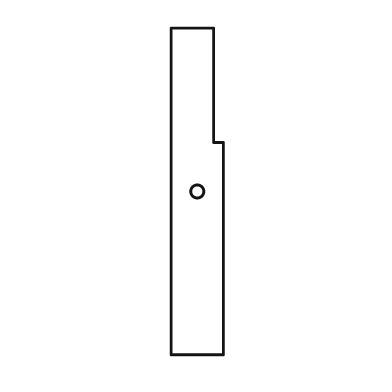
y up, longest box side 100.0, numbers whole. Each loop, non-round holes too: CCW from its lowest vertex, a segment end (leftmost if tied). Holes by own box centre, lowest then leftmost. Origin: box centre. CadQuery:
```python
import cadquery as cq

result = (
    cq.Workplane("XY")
    .moveTo(-8.0, -50.0)
    .lineTo(8.0, -50.0)
    .lineTo(8.0, 15.0)
    .lineTo(5.0, 15.0)
    .lineTo(5.0, 50.0)
    .lineTo(-8.0, 50.0)
    .close()
    .moveTo(0.0, 0.0)
    .circle(2.0)
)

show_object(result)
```